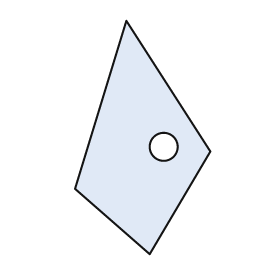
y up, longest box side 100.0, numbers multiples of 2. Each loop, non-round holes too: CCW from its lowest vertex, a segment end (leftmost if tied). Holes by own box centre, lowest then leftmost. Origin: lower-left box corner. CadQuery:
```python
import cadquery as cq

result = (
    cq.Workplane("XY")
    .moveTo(32.0, 0.0)
    .lineTo(58.0, 44.0)
    .lineTo(22.0, 100.0)
    .lineTo(0.0, 28.0)
    .close()
    .moveTo(38.0, 46.0)
    .circle(6.0)
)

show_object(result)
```